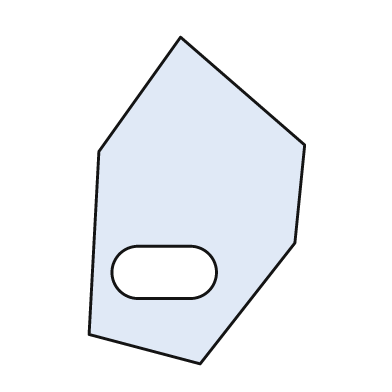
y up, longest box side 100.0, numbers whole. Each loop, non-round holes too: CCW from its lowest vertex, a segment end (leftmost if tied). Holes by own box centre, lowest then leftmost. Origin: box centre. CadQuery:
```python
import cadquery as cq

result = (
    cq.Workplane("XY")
    .moveTo(1.0, -50.0)
    .lineTo(30.0, -13.0)
    .lineTo(33.0, 17.0)
    .lineTo(-5.0, 50.0)
    .lineTo(-30.0, 15.0)
    .lineTo(-33.0, -41.0)
    .close()
    .moveTo(-18.0, -30.0)
    .lineTo(-2.0, -30.0)
    .threePointArc((6.0, -22.0), (-2.0, -14.0))
    .lineTo(-18.0, -14.0)
    .threePointArc((-26.0, -22.0), (-18.0, -30.0))
    .close()
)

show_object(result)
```